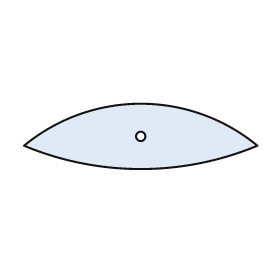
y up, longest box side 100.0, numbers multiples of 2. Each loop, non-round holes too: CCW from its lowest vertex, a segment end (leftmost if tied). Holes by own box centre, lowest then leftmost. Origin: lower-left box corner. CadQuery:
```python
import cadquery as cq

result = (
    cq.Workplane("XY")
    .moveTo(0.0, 10.0)
    .threePointArc((50.0, 0.0), (100.0, 10.0))
    .threePointArc((50.0, 28.0), (0.0, 10.0))
    .close()
    .moveTo(50.0, 14.0)
    .circle(2.0)
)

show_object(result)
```